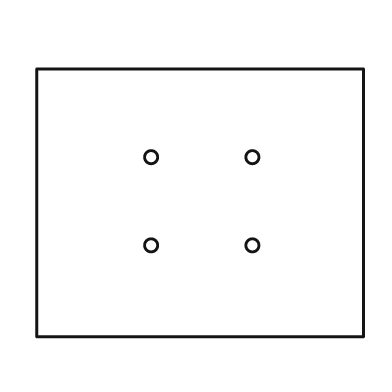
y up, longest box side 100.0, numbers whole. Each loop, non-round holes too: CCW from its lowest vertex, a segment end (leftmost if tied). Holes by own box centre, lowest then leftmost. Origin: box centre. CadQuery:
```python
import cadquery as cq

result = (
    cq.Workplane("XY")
    .moveTo(-50.0, -41.0)
    .lineTo(50.0, -41.0)
    .lineTo(50.0, 41.0)
    .lineTo(-50.0, 41.0)
    .close()
    .moveTo(-15.0, -13.0)
    .circle(2.0)
    .moveTo(16.0, -13.0)
    .circle(2.0)
    .moveTo(-15.0, 14.0)
    .circle(2.0)
    .moveTo(16.0, 14.0)
    .circle(2.0)
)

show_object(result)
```